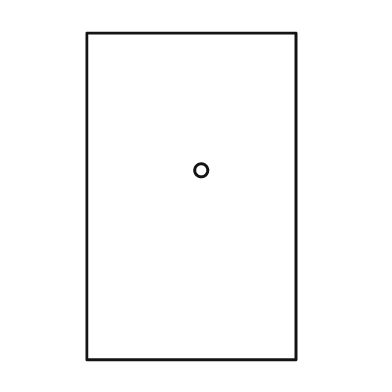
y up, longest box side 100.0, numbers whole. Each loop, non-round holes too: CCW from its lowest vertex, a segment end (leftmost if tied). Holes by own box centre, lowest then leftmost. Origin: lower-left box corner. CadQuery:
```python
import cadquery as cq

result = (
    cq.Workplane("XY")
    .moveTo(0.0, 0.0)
    .lineTo(64.0, 0.0)
    .lineTo(64.0, 100.0)
    .lineTo(0.0, 100.0)
    .close()
    .moveTo(35.0, 58.0)
    .circle(2.0)
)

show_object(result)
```